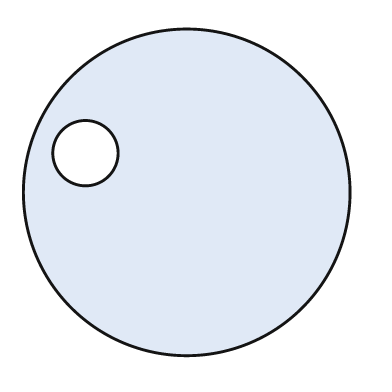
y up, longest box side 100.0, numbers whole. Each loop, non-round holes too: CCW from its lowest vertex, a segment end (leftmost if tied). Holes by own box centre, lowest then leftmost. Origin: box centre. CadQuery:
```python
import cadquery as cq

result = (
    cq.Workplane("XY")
    .moveTo(0.0, 0.0)
    .circle(50.0)
    .moveTo(-31.0, 12.0)
    .circle(10.0)
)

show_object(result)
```